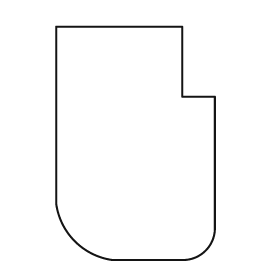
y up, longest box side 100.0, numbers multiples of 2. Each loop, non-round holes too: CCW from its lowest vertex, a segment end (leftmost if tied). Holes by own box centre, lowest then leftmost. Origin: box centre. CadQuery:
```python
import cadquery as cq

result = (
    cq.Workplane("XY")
    .moveTo(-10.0, -50.0)
    .lineTo(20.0, -50.0)
    .threePointArc((30.0, -46.0), (34.0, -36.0))
    .lineTo(34.0, 20.0)
    .lineTo(20.0, 20.0)
    .lineTo(20.0, 50.0)
    .lineTo(-34.0, 50.0)
    .lineTo(-34.0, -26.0)
    .threePointArc((-26.0, -42.0), (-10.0, -50.0))
    .close()
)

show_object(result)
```